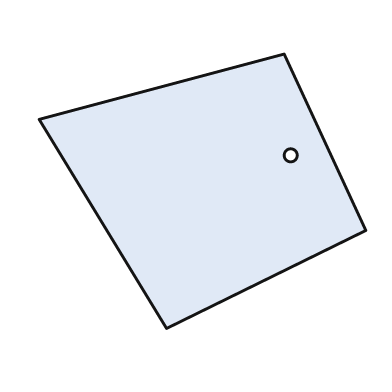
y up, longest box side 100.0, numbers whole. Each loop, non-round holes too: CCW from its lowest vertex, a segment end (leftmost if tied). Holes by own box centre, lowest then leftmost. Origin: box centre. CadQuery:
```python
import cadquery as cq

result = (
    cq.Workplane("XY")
    .moveTo(-11.0, -42.0)
    .lineTo(50.0, -12.0)
    .lineTo(25.0, 42.0)
    .lineTo(-50.0, 22.0)
    .close()
    .moveTo(27.0, 11.0)
    .circle(2.0)
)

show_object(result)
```